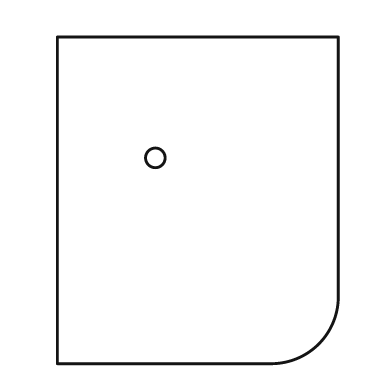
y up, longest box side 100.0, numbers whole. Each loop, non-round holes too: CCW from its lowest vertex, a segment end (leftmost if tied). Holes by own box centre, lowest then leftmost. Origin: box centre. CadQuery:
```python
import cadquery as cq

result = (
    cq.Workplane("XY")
    .moveTo(-43.0, -50.0)
    .lineTo(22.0, -50.0)
    .threePointArc((37.0, -44.0), (43.0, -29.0))
    .lineTo(43.0, 50.0)
    .lineTo(-43.0, 50.0)
    .close()
    .moveTo(-13.0, 13.0)
    .circle(3.0)
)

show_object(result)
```